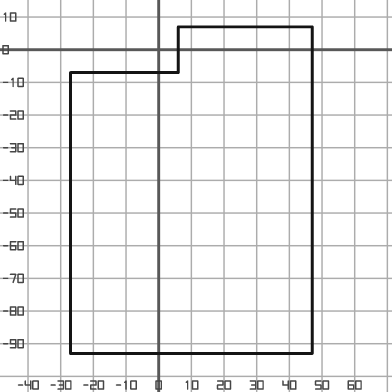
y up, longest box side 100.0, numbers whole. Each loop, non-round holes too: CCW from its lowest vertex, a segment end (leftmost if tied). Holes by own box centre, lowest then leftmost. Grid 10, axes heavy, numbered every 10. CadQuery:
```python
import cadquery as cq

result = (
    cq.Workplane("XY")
    .moveTo(-27.0, -93.0)
    .lineTo(47.0, -93.0)
    .lineTo(47.0, 7.0)
    .lineTo(6.0, 7.0)
    .lineTo(6.0, -7.0)
    .lineTo(-27.0, -7.0)
    .close()
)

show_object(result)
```